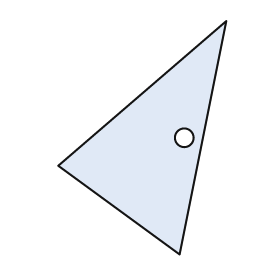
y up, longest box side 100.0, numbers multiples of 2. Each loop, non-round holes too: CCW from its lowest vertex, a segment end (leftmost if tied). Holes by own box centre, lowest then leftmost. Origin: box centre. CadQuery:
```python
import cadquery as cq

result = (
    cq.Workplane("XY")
    .moveTo(16.0, -50.0)
    .lineTo(36.0, 50.0)
    .lineTo(-36.0, -12.0)
    .close()
    .moveTo(18.0, 0.0)
    .circle(4.0)
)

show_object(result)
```